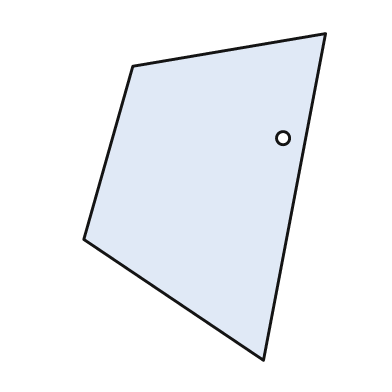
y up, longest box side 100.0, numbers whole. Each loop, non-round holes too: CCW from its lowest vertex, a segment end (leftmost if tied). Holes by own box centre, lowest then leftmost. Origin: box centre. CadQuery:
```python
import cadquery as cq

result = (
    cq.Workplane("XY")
    .moveTo(18.0, -50.0)
    .lineTo(37.0, 50.0)
    .lineTo(-22.0, 40.0)
    .lineTo(-37.0, -13.0)
    .close()
    .moveTo(24.0, 18.0)
    .circle(2.0)
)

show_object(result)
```